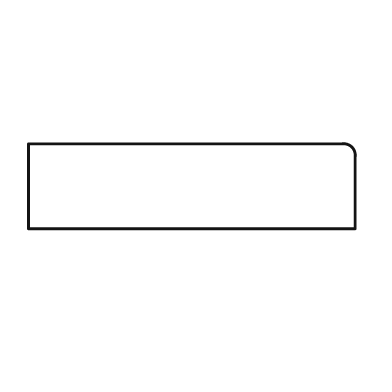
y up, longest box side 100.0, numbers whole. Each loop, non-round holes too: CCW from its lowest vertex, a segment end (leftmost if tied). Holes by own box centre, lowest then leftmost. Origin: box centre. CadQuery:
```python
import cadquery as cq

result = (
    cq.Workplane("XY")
    .moveTo(-50.0, -13.0)
    .lineTo(50.0, -13.0)
    .lineTo(50.0, 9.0)
    .threePointArc((49.0, 12.0), (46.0, 13.0))
    .lineTo(-50.0, 13.0)
    .close()
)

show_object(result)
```